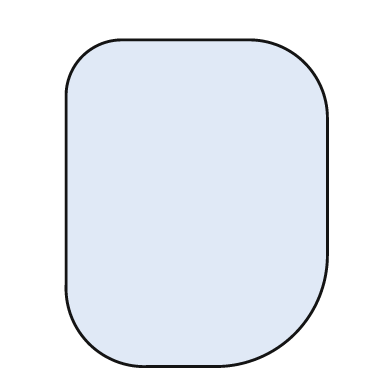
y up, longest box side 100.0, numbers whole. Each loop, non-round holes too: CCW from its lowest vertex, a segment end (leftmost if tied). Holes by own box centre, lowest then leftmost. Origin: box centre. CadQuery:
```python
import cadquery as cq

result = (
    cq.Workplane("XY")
    .moveTo(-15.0, -50.0)
    .lineTo(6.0, -50.0)
    .threePointArc((30.0, -40.0), (40.0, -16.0))
    .lineTo(40.0, 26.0)
    .threePointArc((33.0, 43.0), (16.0, 50.0))
    .lineTo(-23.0, 50.0)
    .threePointArc((-35.0, 45.0), (-40.0, 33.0))
    .lineTo(-40.0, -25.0)
    .threePointArc((-33.0, -43.0), (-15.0, -50.0))
    .close()
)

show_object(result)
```